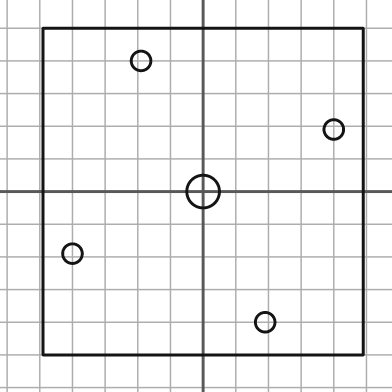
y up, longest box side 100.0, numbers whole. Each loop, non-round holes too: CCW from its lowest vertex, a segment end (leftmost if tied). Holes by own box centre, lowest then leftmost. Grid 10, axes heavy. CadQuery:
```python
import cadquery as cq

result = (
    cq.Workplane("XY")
    .moveTo(-49.0, -50.0)
    .lineTo(49.0, -50.0)
    .lineTo(49.0, 50.0)
    .lineTo(-49.0, 50.0)
    .close()
    .moveTo(19.0, -40.0)
    .circle(3.0)
    .moveTo(-40.0, -19.0)
    .circle(3.0)
    .moveTo(0.0, 0.0)
    .circle(5.0)
    .moveTo(40.0, 19.0)
    .circle(3.0)
    .moveTo(-19.0, 40.0)
    .circle(3.0)
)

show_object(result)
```